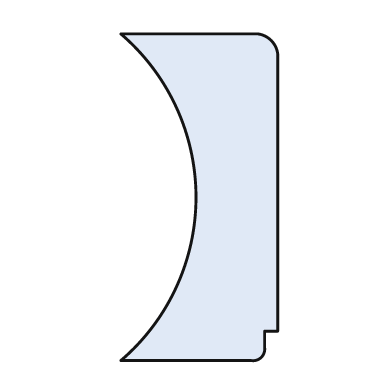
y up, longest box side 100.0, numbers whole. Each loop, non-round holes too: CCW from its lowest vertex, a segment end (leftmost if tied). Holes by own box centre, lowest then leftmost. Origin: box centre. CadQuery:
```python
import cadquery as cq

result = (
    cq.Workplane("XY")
    .moveTo(-24.0, -50.0)
    .lineTo(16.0, -50.0)
    .threePointArc((19.0, -49.0), (20.0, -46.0))
    .lineTo(20.0, -41.0)
    .lineTo(24.0, -41.0)
    .lineTo(24.0, 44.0)
    .threePointArc((22.0, 48.0), (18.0, 50.0))
    .lineTo(-24.0, 50.0)
    .threePointArc((-1.0, 0.0), (-24.0, -50.0))
    .close()
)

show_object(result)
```